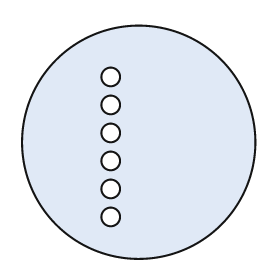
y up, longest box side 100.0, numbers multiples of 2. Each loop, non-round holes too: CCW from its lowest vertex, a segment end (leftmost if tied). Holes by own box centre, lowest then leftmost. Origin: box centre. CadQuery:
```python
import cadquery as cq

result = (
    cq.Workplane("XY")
    .moveTo(0.0, 0.0)
    .circle(50.0)
    .moveTo(-12.0, -32.0)
    .circle(4.0)
    .moveTo(-12.0, -20.0)
    .circle(4.0)
    .moveTo(-12.0, -8.0)
    .circle(4.0)
    .moveTo(-12.0, 4.0)
    .circle(4.0)
    .moveTo(-12.0, 16.0)
    .circle(4.0)
    .moveTo(-12.0, 28.0)
    .circle(4.0)
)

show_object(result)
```